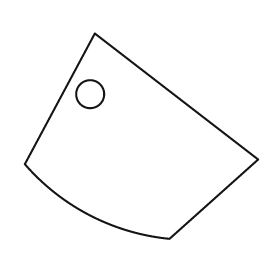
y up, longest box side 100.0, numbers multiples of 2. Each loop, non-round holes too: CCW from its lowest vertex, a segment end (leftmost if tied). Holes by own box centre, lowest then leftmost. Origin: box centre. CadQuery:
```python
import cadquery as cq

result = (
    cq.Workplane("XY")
    .moveTo(12.0, -44.0)
    .lineTo(50.0, -10.0)
    .lineTo(-20.0, 44.0)
    .lineTo(-50.0, -12.0)
    .threePointArc((-22.0, -34.0), (12.0, -44.0))
    .close()
    .moveTo(-22.0, 18.0)
    .circle(6.0)
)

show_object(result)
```